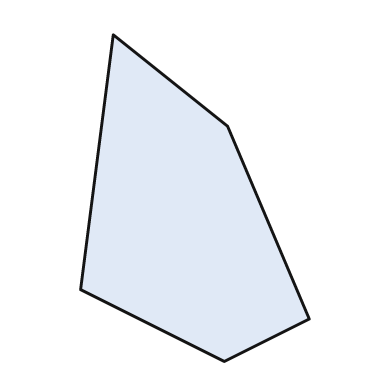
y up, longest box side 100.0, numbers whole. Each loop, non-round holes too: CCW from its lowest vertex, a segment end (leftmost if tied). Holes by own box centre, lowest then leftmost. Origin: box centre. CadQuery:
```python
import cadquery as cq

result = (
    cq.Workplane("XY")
    .moveTo(9.0, -50.0)
    .lineTo(35.0, -37.0)
    .lineTo(10.0, 22.0)
    .lineTo(-25.0, 50.0)
    .lineTo(-35.0, -28.0)
    .close()
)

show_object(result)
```